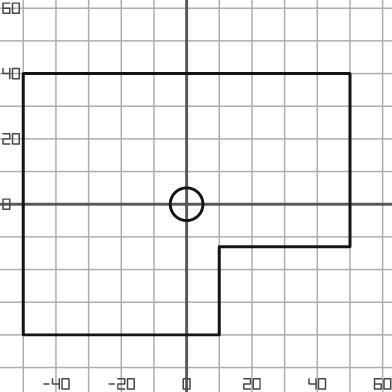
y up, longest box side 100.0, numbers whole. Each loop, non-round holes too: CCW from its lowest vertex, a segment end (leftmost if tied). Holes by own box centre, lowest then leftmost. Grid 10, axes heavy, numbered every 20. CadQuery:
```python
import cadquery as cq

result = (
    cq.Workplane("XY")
    .moveTo(-50.0, -40.0)
    .lineTo(10.0, -40.0)
    .lineTo(10.0, -13.0)
    .lineTo(50.0, -13.0)
    .lineTo(50.0, 40.0)
    .lineTo(-50.0, 40.0)
    .close()
    .moveTo(0.0, 0.0)
    .circle(5.0)
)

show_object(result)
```